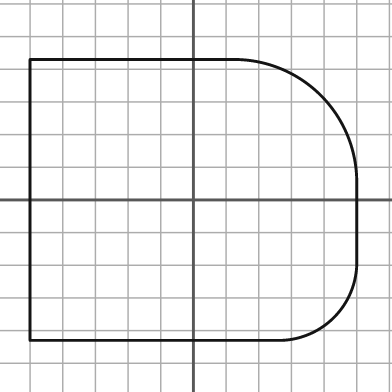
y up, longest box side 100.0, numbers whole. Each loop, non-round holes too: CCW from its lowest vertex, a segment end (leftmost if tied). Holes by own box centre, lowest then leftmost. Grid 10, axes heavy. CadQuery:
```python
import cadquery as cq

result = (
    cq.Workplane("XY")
    .moveTo(-50.0, -43.0)
    .lineTo(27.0, -43.0)
    .threePointArc((43.0, -36.0), (50.0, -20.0))
    .lineTo(50.0, 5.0)
    .threePointArc((39.0, 32.0), (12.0, 43.0))
    .lineTo(-50.0, 43.0)
    .close()
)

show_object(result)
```